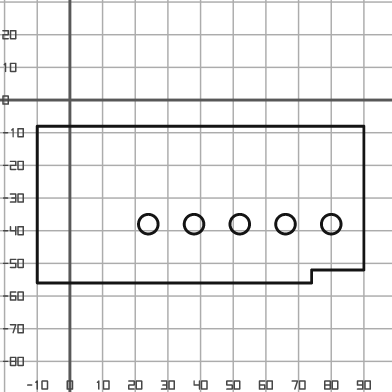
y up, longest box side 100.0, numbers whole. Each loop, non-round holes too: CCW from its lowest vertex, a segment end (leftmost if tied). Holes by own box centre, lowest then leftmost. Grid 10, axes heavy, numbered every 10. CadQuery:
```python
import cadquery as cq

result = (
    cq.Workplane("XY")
    .moveTo(-10.0, -56.0)
    .lineTo(74.0, -56.0)
    .lineTo(74.0, -52.0)
    .lineTo(90.0, -52.0)
    .lineTo(90.0, -8.0)
    .lineTo(-10.0, -8.0)
    .close()
    .moveTo(24.0, -38.0)
    .circle(3.0)
    .moveTo(38.0, -38.0)
    .circle(3.0)
    .moveTo(52.0, -38.0)
    .circle(3.0)
    .moveTo(66.0, -38.0)
    .circle(3.0)
    .moveTo(80.0, -38.0)
    .circle(3.0)
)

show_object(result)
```